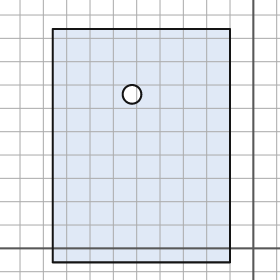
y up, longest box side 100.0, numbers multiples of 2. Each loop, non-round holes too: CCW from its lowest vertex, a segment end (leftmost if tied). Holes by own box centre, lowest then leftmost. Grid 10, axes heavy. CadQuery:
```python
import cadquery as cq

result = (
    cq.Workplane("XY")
    .moveTo(-86.0, -6.0)
    .lineTo(-10.0, -6.0)
    .lineTo(-10.0, 94.0)
    .lineTo(-86.0, 94.0)
    .close()
    .moveTo(-52.0, 66.0)
    .circle(4.0)
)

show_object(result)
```